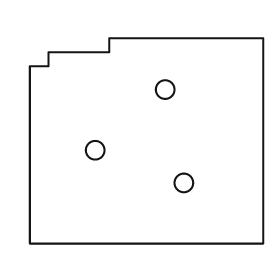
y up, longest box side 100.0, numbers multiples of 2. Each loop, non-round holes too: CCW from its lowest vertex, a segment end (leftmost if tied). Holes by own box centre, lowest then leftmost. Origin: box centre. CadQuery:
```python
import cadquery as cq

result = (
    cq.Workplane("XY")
    .moveTo(-50.0, -44.0)
    .lineTo(50.0, -44.0)
    .lineTo(50.0, 44.0)
    .lineTo(-16.0, 44.0)
    .lineTo(-16.0, 38.0)
    .lineTo(-42.0, 38.0)
    .lineTo(-42.0, 32.0)
    .lineTo(-50.0, 32.0)
    .close()
    .moveTo(16.0, -18.0)
    .circle(4.0)
    .moveTo(-22.0, -4.0)
    .circle(4.0)
    .moveTo(8.0, 22.0)
    .circle(4.0)
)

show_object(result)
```